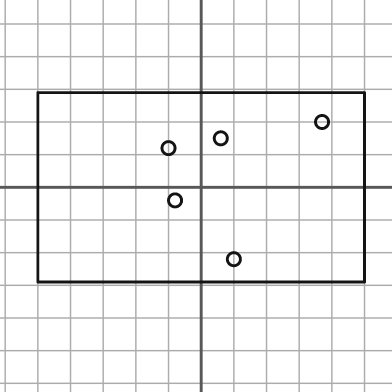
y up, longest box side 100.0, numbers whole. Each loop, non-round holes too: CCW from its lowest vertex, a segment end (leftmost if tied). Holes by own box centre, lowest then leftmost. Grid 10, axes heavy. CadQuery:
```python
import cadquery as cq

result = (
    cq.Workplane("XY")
    .moveTo(-50.0, -29.0)
    .lineTo(50.0, -29.0)
    .lineTo(50.0, 29.0)
    .lineTo(-50.0, 29.0)
    .close()
    .moveTo(10.0, -22.0)
    .circle(2.0)
    .moveTo(-8.0, -4.0)
    .circle(2.0)
    .moveTo(-10.0, 12.0)
    .circle(2.0)
    .moveTo(6.0, 15.0)
    .circle(2.0)
    .moveTo(37.0, 20.0)
    .circle(2.0)
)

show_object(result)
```